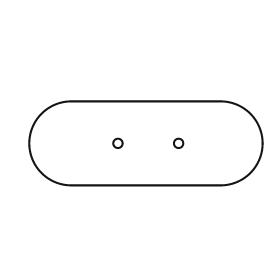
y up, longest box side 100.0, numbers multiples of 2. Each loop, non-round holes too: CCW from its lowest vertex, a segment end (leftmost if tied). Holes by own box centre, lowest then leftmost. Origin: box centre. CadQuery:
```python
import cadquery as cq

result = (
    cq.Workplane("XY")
    .moveTo(-32.0, -18.0)
    .lineTo(32.0, -18.0)
    .threePointArc((50.0, 0.0), (32.0, 18.0))
    .lineTo(-32.0, 18.0)
    .threePointArc((-50.0, 0.0), (-32.0, -18.0))
    .close()
    .moveTo(-12.0, 0.0)
    .circle(2.0)
    .moveTo(14.0, 0.0)
    .circle(2.0)
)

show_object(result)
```